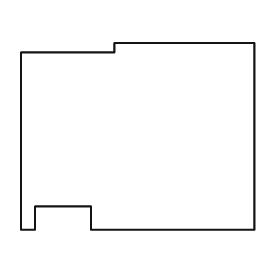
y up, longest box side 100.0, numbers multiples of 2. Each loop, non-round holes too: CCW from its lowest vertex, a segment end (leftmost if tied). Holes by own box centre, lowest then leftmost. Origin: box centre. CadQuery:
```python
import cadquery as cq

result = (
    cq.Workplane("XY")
    .moveTo(-50.0, -40.0)
    .lineTo(-44.0, -40.0)
    .lineTo(-44.0, -30.0)
    .lineTo(-20.0, -30.0)
    .lineTo(-20.0, -40.0)
    .lineTo(50.0, -40.0)
    .lineTo(50.0, 40.0)
    .lineTo(-10.0, 40.0)
    .lineTo(-10.0, 36.0)
    .lineTo(-50.0, 36.0)
    .close()
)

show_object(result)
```